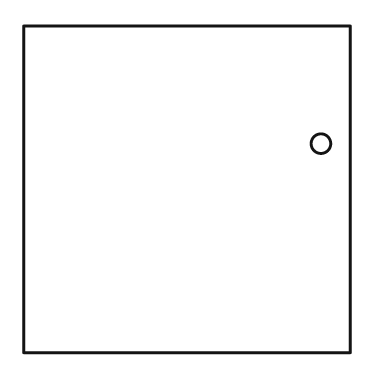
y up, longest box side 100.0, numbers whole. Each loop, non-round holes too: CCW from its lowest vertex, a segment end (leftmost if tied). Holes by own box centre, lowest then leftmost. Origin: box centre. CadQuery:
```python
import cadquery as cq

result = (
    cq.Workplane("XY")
    .moveTo(-50.0, -50.0)
    .lineTo(50.0, -50.0)
    .lineTo(50.0, 50.0)
    .lineTo(-50.0, 50.0)
    .close()
    .moveTo(41.0, 14.0)
    .circle(3.0)
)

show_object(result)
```